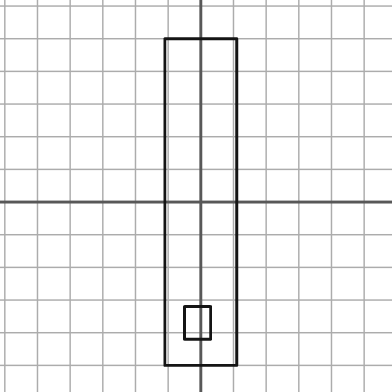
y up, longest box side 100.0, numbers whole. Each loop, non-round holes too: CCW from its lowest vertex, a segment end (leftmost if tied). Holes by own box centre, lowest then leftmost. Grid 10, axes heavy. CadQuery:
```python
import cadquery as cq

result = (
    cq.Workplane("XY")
    .moveTo(-11.0, -50.0)
    .lineTo(11.0, -50.0)
    .lineTo(11.0, 50.0)
    .lineTo(-11.0, 50.0)
    .close()
    .moveTo(-5.0, -42.0)
    .lineTo(3.0, -42.0)
    .lineTo(3.0, -32.0)
    .lineTo(-5.0, -32.0)
    .close()
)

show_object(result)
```